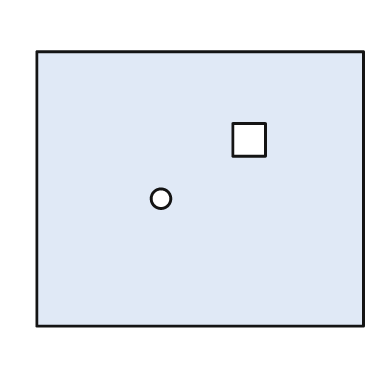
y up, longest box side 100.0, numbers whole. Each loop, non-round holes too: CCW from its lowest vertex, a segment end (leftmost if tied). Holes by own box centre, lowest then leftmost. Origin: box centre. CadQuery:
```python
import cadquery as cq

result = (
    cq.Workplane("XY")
    .moveTo(-50.0, -42.0)
    .lineTo(50.0, -42.0)
    .lineTo(50.0, 42.0)
    .lineTo(-50.0, 42.0)
    .close()
    .moveTo(-12.0, -3.0)
    .circle(3.0)
    .moveTo(10.0, 10.0)
    .lineTo(20.0, 10.0)
    .lineTo(20.0, 20.0)
    .lineTo(10.0, 20.0)
    .close()
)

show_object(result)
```